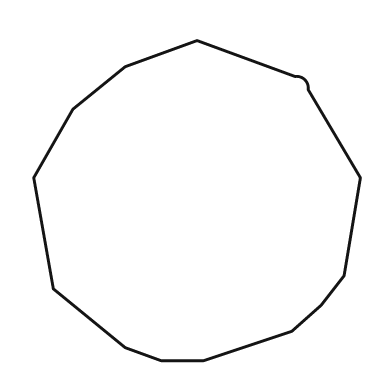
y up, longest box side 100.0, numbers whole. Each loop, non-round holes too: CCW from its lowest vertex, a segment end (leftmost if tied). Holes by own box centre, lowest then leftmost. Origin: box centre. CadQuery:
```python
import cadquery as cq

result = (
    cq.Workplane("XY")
    .moveTo(-11.0, -49.0)
    .lineTo(2.0, -49.0)
    .lineTo(29.0, -40.0)
    .lineTo(38.0, -32.0)
    .lineTo(45.0, -23.0)
    .lineTo(50.0, 7.0)
    .lineTo(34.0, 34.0)
    .threePointArc((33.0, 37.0), (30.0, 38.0))
    .lineTo(0.0, 49.0)
    .lineTo(-22.0, 41.0)
    .lineTo(-38.0, 28.0)
    .lineTo(-50.0, 7.0)
    .lineTo(-44.0, -27.0)
    .lineTo(-22.0, -45.0)
    .close()
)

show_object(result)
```